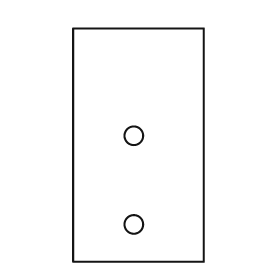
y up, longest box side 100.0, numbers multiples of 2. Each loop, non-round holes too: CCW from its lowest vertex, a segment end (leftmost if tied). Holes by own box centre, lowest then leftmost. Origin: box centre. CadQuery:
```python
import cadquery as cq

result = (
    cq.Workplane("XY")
    .moveTo(-28.0, -50.0)
    .lineTo(28.0, -50.0)
    .lineTo(28.0, 50.0)
    .lineTo(-28.0, 50.0)
    .close()
    .moveTo(-2.0, -34.0)
    .circle(4.0)
    .moveTo(-2.0, 4.0)
    .circle(4.0)
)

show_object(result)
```